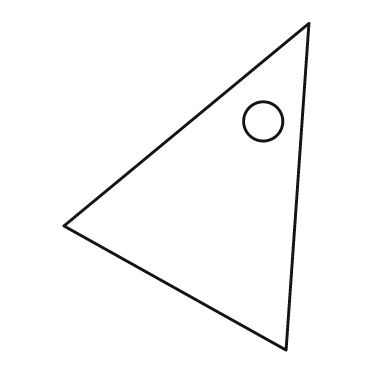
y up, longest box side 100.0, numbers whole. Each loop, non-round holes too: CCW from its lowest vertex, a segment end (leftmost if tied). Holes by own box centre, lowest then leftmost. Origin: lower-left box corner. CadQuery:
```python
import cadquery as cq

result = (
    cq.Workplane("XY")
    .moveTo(68.0, 0.0)
    .lineTo(75.0, 100.0)
    .lineTo(0.0, 38.0)
    .close()
    .moveTo(61.0, 70.0)
    .circle(6.0)
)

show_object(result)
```